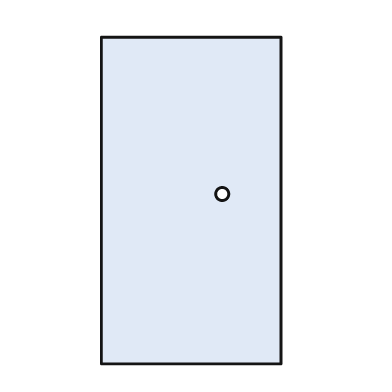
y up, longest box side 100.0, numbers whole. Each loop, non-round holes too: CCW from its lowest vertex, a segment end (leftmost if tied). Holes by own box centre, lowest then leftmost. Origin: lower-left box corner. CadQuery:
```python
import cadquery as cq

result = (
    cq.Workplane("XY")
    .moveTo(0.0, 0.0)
    .lineTo(55.0, 0.0)
    .lineTo(55.0, 100.0)
    .lineTo(0.0, 100.0)
    .close()
    .moveTo(37.0, 52.0)
    .circle(2.0)
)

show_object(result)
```